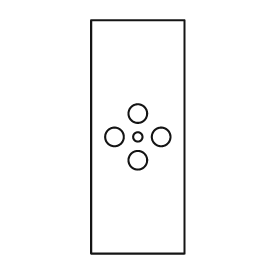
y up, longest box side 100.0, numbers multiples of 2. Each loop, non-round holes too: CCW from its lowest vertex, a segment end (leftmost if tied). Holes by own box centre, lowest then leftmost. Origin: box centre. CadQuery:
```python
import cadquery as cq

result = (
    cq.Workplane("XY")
    .moveTo(-20.0, -50.0)
    .lineTo(20.0, -50.0)
    .lineTo(20.0, 50.0)
    .lineTo(-20.0, 50.0)
    .close()
    .moveTo(0.0, -10.0)
    .circle(4.0)
    .moveTo(-10.0, 0.0)
    .circle(4.0)
    .moveTo(0.0, 0.0)
    .circle(2.0)
    .moveTo(10.0, 0.0)
    .circle(4.0)
    .moveTo(0.0, 10.0)
    .circle(4.0)
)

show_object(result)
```